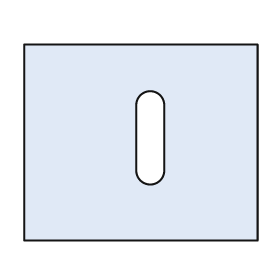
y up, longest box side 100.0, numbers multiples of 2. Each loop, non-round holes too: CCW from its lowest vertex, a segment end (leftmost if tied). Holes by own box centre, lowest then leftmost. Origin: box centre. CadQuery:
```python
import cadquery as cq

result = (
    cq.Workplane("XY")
    .moveTo(-50.0, -42.0)
    .lineTo(50.0, -42.0)
    .lineTo(50.0, 42.0)
    .lineTo(-50.0, 42.0)
    .close()
    .moveTo(-2.0, -12.0)
    .threePointArc((4.0, -18.0), (10.0, -12.0))
    .lineTo(10.0, 16.0)
    .threePointArc((4.0, 22.0), (-2.0, 16.0))
    .close()
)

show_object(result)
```